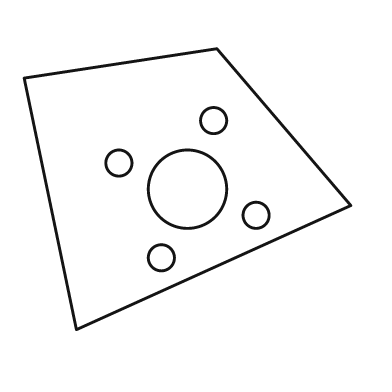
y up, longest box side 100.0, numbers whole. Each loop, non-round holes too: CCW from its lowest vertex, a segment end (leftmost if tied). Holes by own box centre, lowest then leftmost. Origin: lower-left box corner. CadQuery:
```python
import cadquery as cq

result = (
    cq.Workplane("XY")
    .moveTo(16.0, 0.0)
    .lineTo(100.0, 38.0)
    .lineTo(59.0, 86.0)
    .lineTo(0.0, 77.0)
    .close()
    .moveTo(42.0, 22.0)
    .circle(4.0)
    .moveTo(71.0, 35.0)
    .circle(4.0)
    .moveTo(50.0, 43.0)
    .circle(12.0)
    .moveTo(29.0, 51.0)
    .circle(4.0)
    .moveTo(58.0, 64.0)
    .circle(4.0)
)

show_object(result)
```